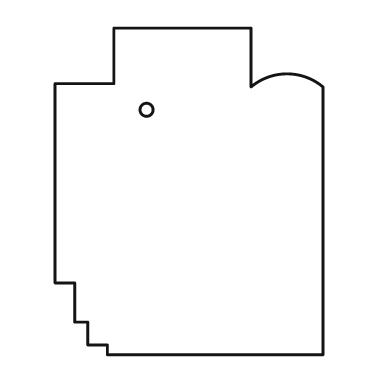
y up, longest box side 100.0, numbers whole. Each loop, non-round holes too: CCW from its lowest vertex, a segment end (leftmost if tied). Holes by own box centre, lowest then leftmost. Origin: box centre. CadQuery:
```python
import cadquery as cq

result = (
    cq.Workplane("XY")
    .moveTo(-25.0, -50.0)
    .lineTo(41.0, -50.0)
    .lineTo(41.0, 32.0)
    .threePointArc((30.0, 36.0), (19.0, 32.0))
    .lineTo(19.0, 50.0)
    .lineTo(-23.0, 50.0)
    .lineTo(-23.0, 33.0)
    .lineTo(-41.0, 33.0)
    .lineTo(-41.0, -28.0)
    .lineTo(-35.0, -28.0)
    .lineTo(-35.0, -40.0)
    .lineTo(-31.0, -40.0)
    .lineTo(-31.0, -47.0)
    .lineTo(-25.0, -47.0)
    .close()
    .moveTo(-13.0, 25.0)
    .circle(2.0)
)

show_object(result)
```